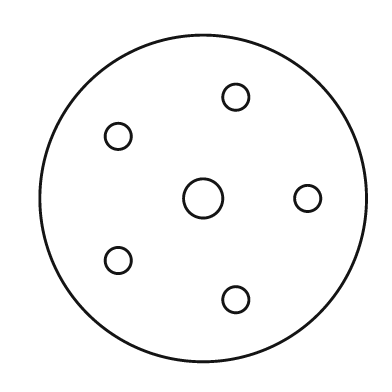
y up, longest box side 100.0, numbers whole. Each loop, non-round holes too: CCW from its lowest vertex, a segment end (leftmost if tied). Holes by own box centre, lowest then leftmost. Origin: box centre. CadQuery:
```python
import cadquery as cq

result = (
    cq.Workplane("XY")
    .moveTo(0.0, 0.0)
    .circle(50.0)
    .moveTo(10.0, -31.0)
    .circle(4.0)
    .moveTo(-26.0, -19.0)
    .circle(4.0)
    .moveTo(0.0, 0.0)
    .circle(6.0)
    .moveTo(32.0, 0.0)
    .circle(4.0)
    .moveTo(-26.0, 19.0)
    .circle(4.0)
    .moveTo(10.0, 31.0)
    .circle(4.0)
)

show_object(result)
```